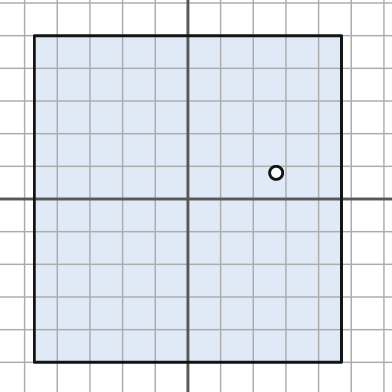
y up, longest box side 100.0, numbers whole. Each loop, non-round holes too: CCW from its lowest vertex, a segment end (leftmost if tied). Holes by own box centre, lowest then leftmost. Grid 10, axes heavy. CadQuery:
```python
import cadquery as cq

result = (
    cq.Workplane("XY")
    .moveTo(-47.0, -50.0)
    .lineTo(47.0, -50.0)
    .lineTo(47.0, 50.0)
    .lineTo(-47.0, 50.0)
    .close()
    .moveTo(27.0, 8.0)
    .circle(2.0)
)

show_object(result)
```